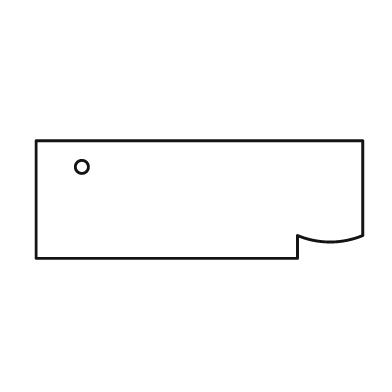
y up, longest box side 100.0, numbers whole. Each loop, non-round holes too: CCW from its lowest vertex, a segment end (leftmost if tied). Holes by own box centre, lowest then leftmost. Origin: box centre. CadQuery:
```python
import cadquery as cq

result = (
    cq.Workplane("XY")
    .moveTo(-50.0, -18.0)
    .lineTo(30.0, -18.0)
    .lineTo(30.0, -11.0)
    .threePointArc((40.0, -13.0), (50.0, -11.0))
    .lineTo(50.0, 18.0)
    .lineTo(-50.0, 18.0)
    .close()
    .moveTo(-36.0, 10.0)
    .circle(2.0)
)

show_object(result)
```